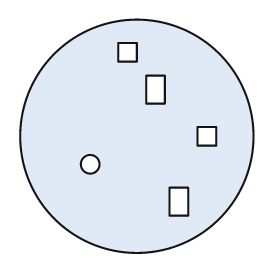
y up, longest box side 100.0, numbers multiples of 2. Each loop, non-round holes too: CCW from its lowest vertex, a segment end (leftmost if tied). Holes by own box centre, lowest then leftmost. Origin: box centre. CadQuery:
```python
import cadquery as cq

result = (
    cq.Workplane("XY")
    .moveTo(0.0, 0.0)
    .circle(50.0)
    .moveTo(14.0, -34.0)
    .lineTo(22.0, -34.0)
    .lineTo(22.0, -22.0)
    .lineTo(14.0, -22.0)
    .close()
    .moveTo(-20.0, -12.0)
    .circle(4.0)
    .moveTo(26.0, -4.0)
    .lineTo(34.0, -4.0)
    .lineTo(34.0, 4.0)
    .lineTo(26.0, 4.0)
    .close()
    .moveTo(4.0, 14.0)
    .lineTo(12.0, 14.0)
    .lineTo(12.0, 26.0)
    .lineTo(4.0, 26.0)
    .close()
    .moveTo(-8.0, 32.0)
    .lineTo(0.0, 32.0)
    .lineTo(0.0, 40.0)
    .lineTo(-8.0, 40.0)
    .close()
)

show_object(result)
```